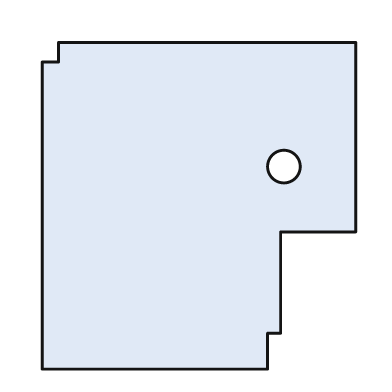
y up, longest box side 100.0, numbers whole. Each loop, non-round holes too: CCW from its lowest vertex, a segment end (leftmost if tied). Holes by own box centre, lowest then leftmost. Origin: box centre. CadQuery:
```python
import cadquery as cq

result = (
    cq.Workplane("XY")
    .moveTo(-48.0, -50.0)
    .lineTo(21.0, -50.0)
    .lineTo(21.0, -39.0)
    .lineTo(25.0, -39.0)
    .lineTo(25.0, -8.0)
    .lineTo(48.0, -8.0)
    .lineTo(48.0, 50.0)
    .lineTo(-43.0, 50.0)
    .lineTo(-43.0, 44.0)
    .lineTo(-48.0, 44.0)
    .close()
    .moveTo(26.0, 12.0)
    .circle(5.0)
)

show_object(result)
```